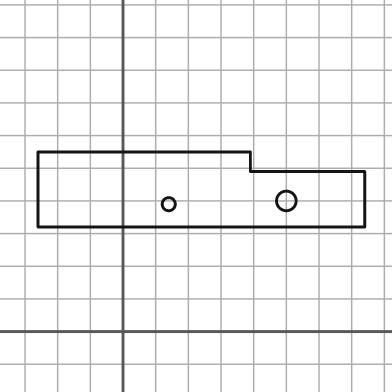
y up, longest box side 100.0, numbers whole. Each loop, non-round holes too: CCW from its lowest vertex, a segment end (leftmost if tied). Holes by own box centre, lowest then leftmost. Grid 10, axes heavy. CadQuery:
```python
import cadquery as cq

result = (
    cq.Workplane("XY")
    .moveTo(-26.0, 32.0)
    .lineTo(74.0, 32.0)
    .lineTo(74.0, 49.0)
    .lineTo(39.0, 49.0)
    .lineTo(39.0, 55.0)
    .lineTo(-26.0, 55.0)
    .close()
    .moveTo(14.0, 39.0)
    .circle(2.0)
    .moveTo(50.0, 40.0)
    .circle(3.0)
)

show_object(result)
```